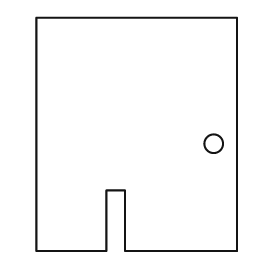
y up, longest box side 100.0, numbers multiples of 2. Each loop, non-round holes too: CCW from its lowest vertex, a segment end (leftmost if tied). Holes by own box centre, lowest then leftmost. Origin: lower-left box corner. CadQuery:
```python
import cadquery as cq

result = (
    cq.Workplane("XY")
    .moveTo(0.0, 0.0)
    .lineTo(30.0, 0.0)
    .lineTo(30.0, 26.0)
    .lineTo(38.0, 26.0)
    .lineTo(38.0, 0.0)
    .lineTo(86.0, 0.0)
    .lineTo(86.0, 100.0)
    .lineTo(0.0, 100.0)
    .close()
    .moveTo(76.0, 46.0)
    .circle(4.0)
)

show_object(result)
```